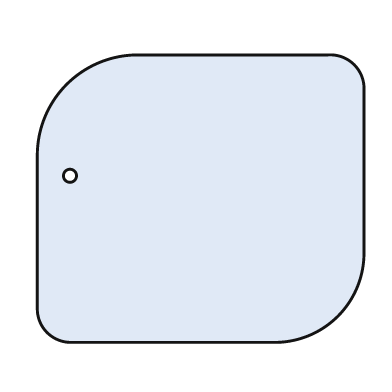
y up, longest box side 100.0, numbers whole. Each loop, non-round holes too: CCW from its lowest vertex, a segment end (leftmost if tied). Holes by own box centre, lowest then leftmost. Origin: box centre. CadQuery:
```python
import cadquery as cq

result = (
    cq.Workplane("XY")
    .moveTo(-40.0, -44.0)
    .lineTo(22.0, -44.0)
    .threePointArc((42.0, -36.0), (50.0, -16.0))
    .lineTo(50.0, 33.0)
    .threePointArc((47.0, 41.0), (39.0, 44.0))
    .lineTo(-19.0, 44.0)
    .threePointArc((-41.0, 35.0), (-50.0, 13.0))
    .lineTo(-50.0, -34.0)
    .threePointArc((-47.0, -41.0), (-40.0, -44.0))
    .close()
    .moveTo(-40.0, 7.0)
    .circle(2.0)
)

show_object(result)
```